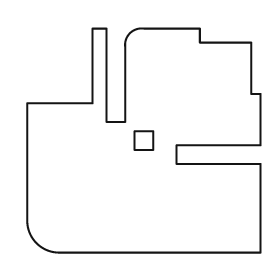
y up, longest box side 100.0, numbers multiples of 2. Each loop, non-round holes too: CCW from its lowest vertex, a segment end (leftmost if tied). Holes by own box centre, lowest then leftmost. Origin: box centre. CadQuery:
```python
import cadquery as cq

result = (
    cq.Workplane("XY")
    .moveTo(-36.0, -48.0)
    .lineTo(50.0, -48.0)
    .lineTo(50.0, -10.0)
    .lineTo(14.0, -10.0)
    .lineTo(14.0, -2.0)
    .lineTo(50.0, -2.0)
    .lineTo(50.0, 20.0)
    .lineTo(46.0, 20.0)
    .lineTo(46.0, 42.0)
    .lineTo(24.0, 42.0)
    .lineTo(24.0, 48.0)
    .lineTo(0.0, 48.0)
    .threePointArc((-6.0, 46.0), (-8.0, 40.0))
    .lineTo(-8.0, 8.0)
    .lineTo(-16.0, 8.0)
    .lineTo(-16.0, 48.0)
    .lineTo(-22.0, 48.0)
    .lineTo(-22.0, 16.0)
    .lineTo(-50.0, 16.0)
    .lineTo(-50.0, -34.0)
    .threePointArc((-46.0, -44.0), (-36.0, -48.0))
    .close()
    .moveTo(-4.0, -4.0)
    .lineTo(4.0, -4.0)
    .lineTo(4.0, 4.0)
    .lineTo(-4.0, 4.0)
    .close()
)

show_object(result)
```